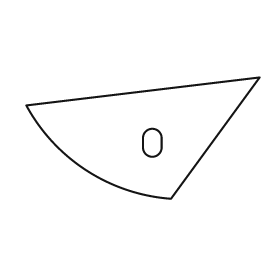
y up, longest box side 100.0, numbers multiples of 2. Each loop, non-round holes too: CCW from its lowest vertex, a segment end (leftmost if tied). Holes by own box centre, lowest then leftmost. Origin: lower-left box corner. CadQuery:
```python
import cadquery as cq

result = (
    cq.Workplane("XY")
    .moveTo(62.0, 0.0)
    .lineTo(100.0, 52.0)
    .lineTo(0.0, 40.0)
    .threePointArc((26.0, 12.0), (62.0, 0.0))
    .close()
    .moveTo(50.0, 22.0)
    .threePointArc((54.0, 18.0), (58.0, 22.0))
    .lineTo(58.0, 26.0)
    .threePointArc((54.0, 30.0), (50.0, 26.0))
    .close()
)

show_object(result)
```